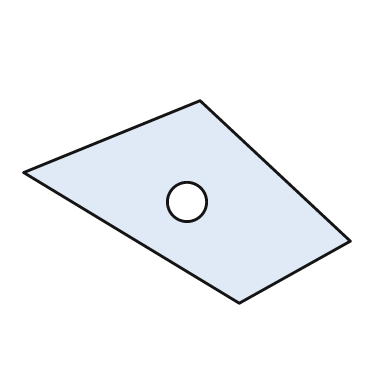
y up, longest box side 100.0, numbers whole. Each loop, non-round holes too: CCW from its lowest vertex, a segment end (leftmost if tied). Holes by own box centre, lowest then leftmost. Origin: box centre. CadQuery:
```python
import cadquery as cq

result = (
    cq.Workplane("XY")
    .moveTo(16.0, -31.0)
    .lineTo(50.0, -12.0)
    .lineTo(4.0, 31.0)
    .lineTo(-50.0, 9.0)
    .close()
    .moveTo(0.0, 0.0)
    .circle(6.0)
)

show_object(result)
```